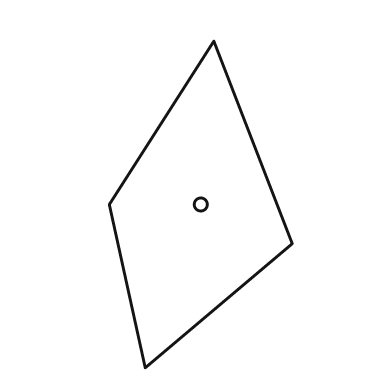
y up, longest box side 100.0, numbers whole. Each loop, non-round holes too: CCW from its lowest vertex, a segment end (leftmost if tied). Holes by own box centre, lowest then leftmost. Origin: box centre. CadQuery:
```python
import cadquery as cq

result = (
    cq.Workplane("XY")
    .moveTo(-17.0, -50.0)
    .lineTo(28.0, -12.0)
    .lineTo(4.0, 50.0)
    .lineTo(-28.0, 0.0)
    .close()
    .moveTo(0.0, 0.0)
    .circle(2.0)
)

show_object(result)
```